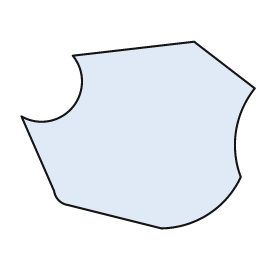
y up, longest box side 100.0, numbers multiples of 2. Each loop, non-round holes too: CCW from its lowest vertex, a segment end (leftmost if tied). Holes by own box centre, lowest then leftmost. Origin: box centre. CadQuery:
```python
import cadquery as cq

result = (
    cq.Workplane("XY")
    .moveTo(10.0, -40.0)
    .threePointArc((30.0, -34.0), (44.0, -18.0))
    .threePointArc((42.0, 2.0), (50.0, 20.0))
    .lineTo(24.0, 40.0)
    .lineTo(-28.0, 34.0)
    .threePointArc((-28.0, 12.0), (-50.0, 8.0))
    .lineTo(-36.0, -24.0)
    .threePointArc((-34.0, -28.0), (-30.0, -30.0))
    .close()
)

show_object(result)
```